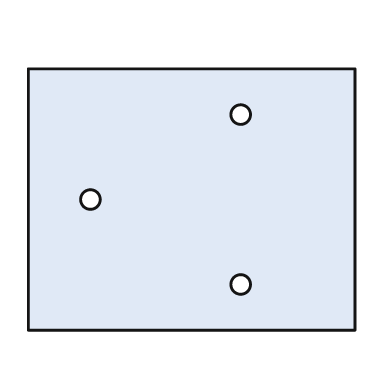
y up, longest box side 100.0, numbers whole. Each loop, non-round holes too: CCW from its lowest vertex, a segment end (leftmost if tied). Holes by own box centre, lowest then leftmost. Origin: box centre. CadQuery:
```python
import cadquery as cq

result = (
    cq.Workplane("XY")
    .moveTo(-50.0, -40.0)
    .lineTo(50.0, -40.0)
    .lineTo(50.0, 40.0)
    .lineTo(-50.0, 40.0)
    .close()
    .moveTo(15.0, -26.0)
    .circle(3.0)
    .moveTo(-31.0, 0.0)
    .circle(3.0)
    .moveTo(15.0, 26.0)
    .circle(3.0)
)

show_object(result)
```